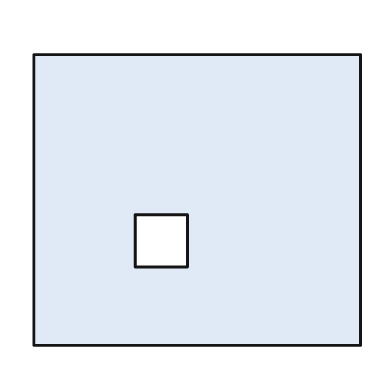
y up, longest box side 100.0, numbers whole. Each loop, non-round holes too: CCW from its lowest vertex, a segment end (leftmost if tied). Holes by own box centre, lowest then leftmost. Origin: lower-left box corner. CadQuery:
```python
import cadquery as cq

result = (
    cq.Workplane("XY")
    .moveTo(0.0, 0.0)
    .lineTo(100.0, 0.0)
    .lineTo(100.0, 89.0)
    .lineTo(0.0, 89.0)
    .close()
    .moveTo(31.0, 24.0)
    .lineTo(47.0, 24.0)
    .lineTo(47.0, 40.0)
    .lineTo(31.0, 40.0)
    .close()
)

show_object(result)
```